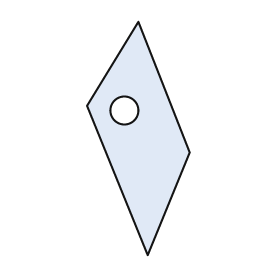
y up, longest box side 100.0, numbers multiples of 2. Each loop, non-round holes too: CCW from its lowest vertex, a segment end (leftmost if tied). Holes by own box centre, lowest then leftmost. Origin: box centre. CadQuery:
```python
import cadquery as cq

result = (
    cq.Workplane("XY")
    .moveTo(4.0, -50.0)
    .lineTo(22.0, -6.0)
    .lineTo(0.0, 50.0)
    .lineTo(-22.0, 14.0)
    .close()
    .moveTo(-6.0, 12.0)
    .circle(6.0)
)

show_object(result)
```